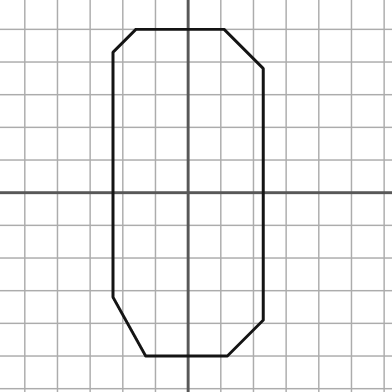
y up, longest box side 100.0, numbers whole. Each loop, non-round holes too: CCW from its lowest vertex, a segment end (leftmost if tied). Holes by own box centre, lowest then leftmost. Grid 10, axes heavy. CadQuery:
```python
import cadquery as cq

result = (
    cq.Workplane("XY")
    .moveTo(-13.0, -50.0)
    .lineTo(12.0, -50.0)
    .lineTo(23.0, -39.0)
    .lineTo(23.0, 38.0)
    .lineTo(11.0, 50.0)
    .lineTo(-16.0, 50.0)
    .lineTo(-23.0, 43.0)
    .lineTo(-23.0, -32.0)
    .close()
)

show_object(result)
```